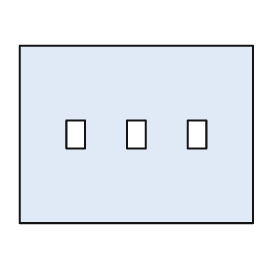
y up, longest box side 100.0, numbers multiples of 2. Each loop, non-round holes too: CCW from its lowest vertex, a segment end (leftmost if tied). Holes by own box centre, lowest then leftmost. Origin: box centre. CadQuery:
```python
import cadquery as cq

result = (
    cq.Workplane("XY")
    .moveTo(-50.0, -38.0)
    .lineTo(50.0, -38.0)
    .lineTo(50.0, 38.0)
    .lineTo(-50.0, 38.0)
    .close()
    .moveTo(-30.0, -6.0)
    .lineTo(-22.0, -6.0)
    .lineTo(-22.0, 6.0)
    .lineTo(-30.0, 6.0)
    .close()
    .moveTo(-4.0, -6.0)
    .lineTo(4.0, -6.0)
    .lineTo(4.0, 6.0)
    .lineTo(-4.0, 6.0)
    .close()
    .moveTo(22.0, -6.0)
    .lineTo(30.0, -6.0)
    .lineTo(30.0, 6.0)
    .lineTo(22.0, 6.0)
    .close()
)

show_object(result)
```